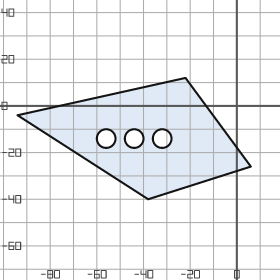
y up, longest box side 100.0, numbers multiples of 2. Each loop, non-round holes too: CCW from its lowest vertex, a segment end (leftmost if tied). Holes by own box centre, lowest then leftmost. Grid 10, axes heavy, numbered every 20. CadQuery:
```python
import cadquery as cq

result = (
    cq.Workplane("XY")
    .moveTo(-38.0, -40.0)
    .lineTo(6.0, -26.0)
    .lineTo(-22.0, 12.0)
    .lineTo(-94.0, -4.0)
    .close()
    .moveTo(-56.0, -14.0)
    .circle(4.0)
    .moveTo(-44.0, -14.0)
    .circle(4.0)
    .moveTo(-32.0, -14.0)
    .circle(4.0)
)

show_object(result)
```